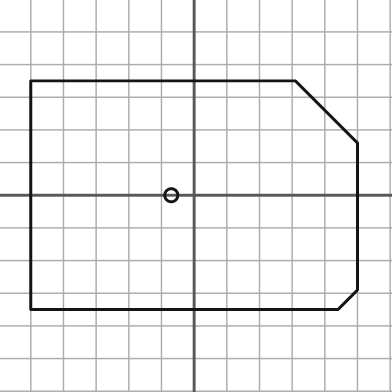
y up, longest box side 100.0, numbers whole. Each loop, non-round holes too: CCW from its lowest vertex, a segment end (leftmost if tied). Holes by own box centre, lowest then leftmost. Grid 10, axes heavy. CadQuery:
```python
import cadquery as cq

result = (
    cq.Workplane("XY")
    .moveTo(-50.0, -35.0)
    .lineTo(44.0, -35.0)
    .lineTo(50.0, -29.0)
    .lineTo(50.0, 16.0)
    .lineTo(31.0, 35.0)
    .lineTo(-50.0, 35.0)
    .close()
    .moveTo(-7.0, 0.0)
    .circle(2.0)
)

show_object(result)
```